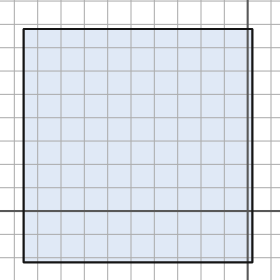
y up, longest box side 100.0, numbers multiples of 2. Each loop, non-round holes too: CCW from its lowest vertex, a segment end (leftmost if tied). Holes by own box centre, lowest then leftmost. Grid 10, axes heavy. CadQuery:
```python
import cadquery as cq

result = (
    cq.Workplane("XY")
    .moveTo(-96.0, -22.0)
    .lineTo(2.0, -22.0)
    .lineTo(2.0, 78.0)
    .lineTo(-96.0, 78.0)
    .close()
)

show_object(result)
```